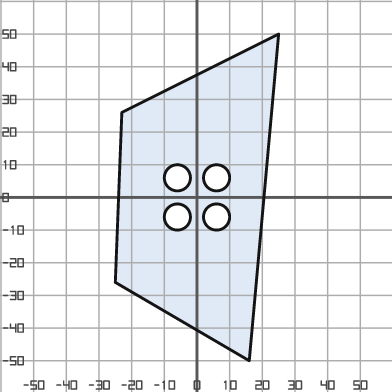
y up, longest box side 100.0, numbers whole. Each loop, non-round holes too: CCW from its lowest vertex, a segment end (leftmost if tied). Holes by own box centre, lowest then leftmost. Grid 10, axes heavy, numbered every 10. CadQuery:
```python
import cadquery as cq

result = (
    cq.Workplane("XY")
    .moveTo(16.0, -50.0)
    .lineTo(25.0, 50.0)
    .lineTo(-23.0, 26.0)
    .lineTo(-25.0, -26.0)
    .close()
    .moveTo(-6.0, -6.0)
    .circle(4.0)
    .moveTo(6.0, -6.0)
    .circle(4.0)
    .moveTo(-6.0, 6.0)
    .circle(4.0)
    .moveTo(6.0, 6.0)
    .circle(4.0)
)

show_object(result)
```